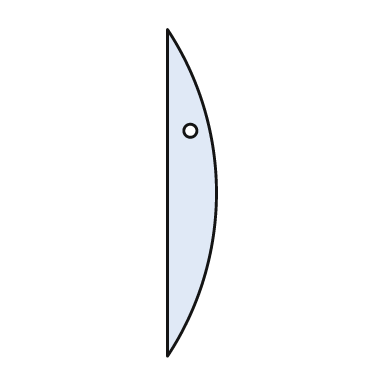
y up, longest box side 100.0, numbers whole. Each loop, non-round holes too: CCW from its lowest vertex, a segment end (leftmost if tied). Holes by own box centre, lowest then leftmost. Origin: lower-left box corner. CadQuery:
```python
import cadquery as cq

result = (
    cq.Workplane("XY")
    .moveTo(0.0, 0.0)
    .threePointArc((15.0, 50.0), (0.0, 100.0))
    .close()
    .moveTo(7.0, 69.0)
    .circle(2.0)
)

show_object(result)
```